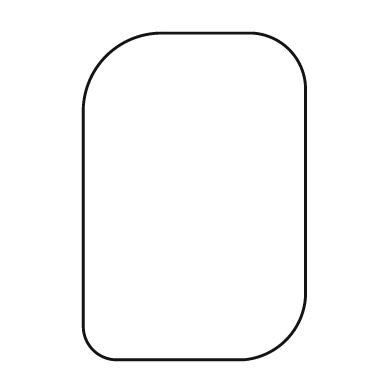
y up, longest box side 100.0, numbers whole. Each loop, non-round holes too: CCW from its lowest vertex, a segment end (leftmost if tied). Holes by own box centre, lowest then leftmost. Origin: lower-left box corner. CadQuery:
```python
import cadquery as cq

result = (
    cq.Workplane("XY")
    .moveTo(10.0, 0.0)
    .lineTo(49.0, 0.0)
    .threePointArc((62.0, 6.0), (68.0, 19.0))
    .lineTo(68.0, 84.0)
    .threePointArc((63.0, 95.0), (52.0, 100.0))
    .lineTo(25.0, 100.0)
    .threePointArc((7.0, 93.0), (0.0, 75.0))
    .lineTo(0.0, 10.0)
    .threePointArc((3.0, 3.0), (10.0, 0.0))
    .close()
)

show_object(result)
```